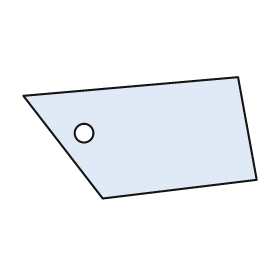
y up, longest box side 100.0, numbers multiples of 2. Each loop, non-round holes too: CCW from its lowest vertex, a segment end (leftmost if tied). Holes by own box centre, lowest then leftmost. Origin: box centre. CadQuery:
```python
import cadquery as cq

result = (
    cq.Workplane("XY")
    .moveTo(-16.0, -26.0)
    .lineTo(50.0, -18.0)
    .lineTo(42.0, 26.0)
    .lineTo(-50.0, 18.0)
    .close()
    .moveTo(-24.0, 2.0)
    .circle(4.0)
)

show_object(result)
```